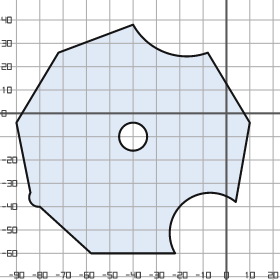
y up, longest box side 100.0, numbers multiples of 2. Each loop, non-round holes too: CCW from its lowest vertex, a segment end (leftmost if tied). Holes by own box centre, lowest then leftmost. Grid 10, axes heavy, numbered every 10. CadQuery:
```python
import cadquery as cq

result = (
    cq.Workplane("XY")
    .moveTo(-58.0, -60.0)
    .lineTo(-22.0, -60.0)
    .threePointArc((-18.0, -38.0), (4.0, -38.0))
    .lineTo(10.0, -4.0)
    .lineTo(-8.0, 26.0)
    .threePointArc((-26.0, 26.0), (-40.0, 38.0))
    .lineTo(-72.0, 26.0)
    .lineTo(-90.0, -4.0)
    .lineTo(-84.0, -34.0)
    .threePointArc((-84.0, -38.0), (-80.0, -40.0))
    .close()
    .moveTo(-40.0, -10.0)
    .circle(6.0)
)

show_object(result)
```